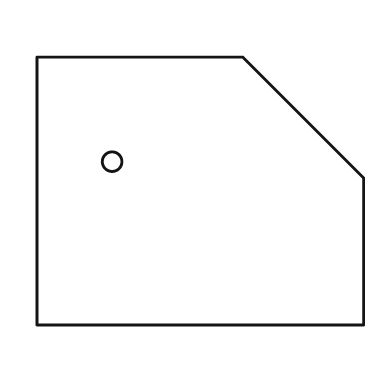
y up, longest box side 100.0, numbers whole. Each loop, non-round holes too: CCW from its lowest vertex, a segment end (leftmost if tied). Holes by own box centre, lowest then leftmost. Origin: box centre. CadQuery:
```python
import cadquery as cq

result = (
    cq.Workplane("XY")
    .moveTo(-50.0, -41.0)
    .lineTo(50.0, -41.0)
    .lineTo(50.0, 4.0)
    .lineTo(13.0, 41.0)
    .lineTo(-50.0, 41.0)
    .close()
    .moveTo(-27.0, 9.0)
    .circle(3.0)
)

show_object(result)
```